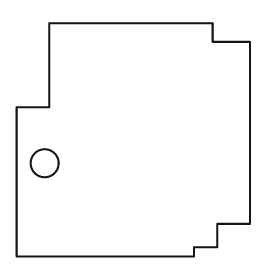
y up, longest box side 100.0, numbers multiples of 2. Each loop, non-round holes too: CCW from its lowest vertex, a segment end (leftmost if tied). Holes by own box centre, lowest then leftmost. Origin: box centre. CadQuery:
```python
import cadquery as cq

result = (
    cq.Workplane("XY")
    .moveTo(-50.0, -50.0)
    .lineTo(26.0, -50.0)
    .lineTo(26.0, -46.0)
    .lineTo(36.0, -46.0)
    .lineTo(36.0, -36.0)
    .lineTo(50.0, -36.0)
    .lineTo(50.0, 42.0)
    .lineTo(34.0, 42.0)
    .lineTo(34.0, 50.0)
    .lineTo(-36.0, 50.0)
    .lineTo(-36.0, 14.0)
    .lineTo(-50.0, 14.0)
    .close()
    .moveTo(-38.0, -10.0)
    .circle(6.0)
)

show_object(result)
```